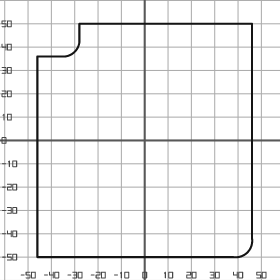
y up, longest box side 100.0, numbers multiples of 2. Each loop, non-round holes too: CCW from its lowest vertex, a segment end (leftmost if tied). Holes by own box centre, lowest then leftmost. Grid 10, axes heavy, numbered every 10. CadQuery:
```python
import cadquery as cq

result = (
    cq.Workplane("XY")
    .moveTo(-46.0, -50.0)
    .lineTo(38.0, -50.0)
    .threePointArc((44.0, -48.0), (46.0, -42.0))
    .lineTo(46.0, 50.0)
    .lineTo(-28.0, 50.0)
    .lineTo(-28.0, 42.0)
    .threePointArc((-30.0, 38.0), (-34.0, 36.0))
    .lineTo(-46.0, 36.0)
    .close()
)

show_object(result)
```